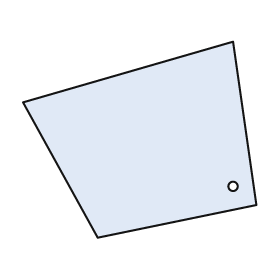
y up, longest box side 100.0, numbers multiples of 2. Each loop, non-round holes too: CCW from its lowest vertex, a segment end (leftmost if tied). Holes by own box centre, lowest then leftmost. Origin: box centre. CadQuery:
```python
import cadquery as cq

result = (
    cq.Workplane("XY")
    .moveTo(-18.0, -42.0)
    .lineTo(50.0, -28.0)
    .lineTo(40.0, 42.0)
    .lineTo(-50.0, 16.0)
    .close()
    .moveTo(40.0, -20.0)
    .circle(2.0)
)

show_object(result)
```